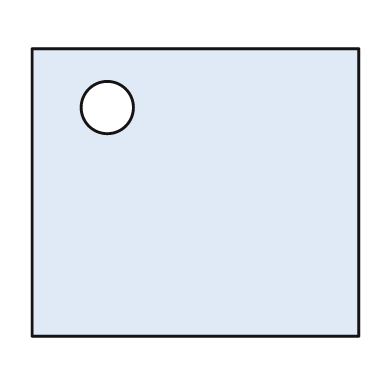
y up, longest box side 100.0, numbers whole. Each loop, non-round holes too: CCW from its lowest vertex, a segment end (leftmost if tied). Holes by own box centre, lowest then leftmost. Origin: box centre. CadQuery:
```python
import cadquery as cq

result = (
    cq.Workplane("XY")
    .moveTo(-50.0, -44.0)
    .lineTo(50.0, -44.0)
    .lineTo(50.0, 44.0)
    .lineTo(-50.0, 44.0)
    .close()
    .moveTo(-27.0, 26.0)
    .circle(8.0)
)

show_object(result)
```